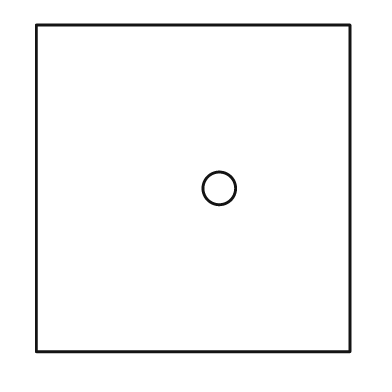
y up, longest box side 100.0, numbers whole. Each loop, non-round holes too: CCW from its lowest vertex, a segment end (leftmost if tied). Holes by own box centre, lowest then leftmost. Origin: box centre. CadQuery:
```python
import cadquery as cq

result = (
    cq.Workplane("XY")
    .moveTo(-48.0, -50.0)
    .lineTo(48.0, -50.0)
    .lineTo(48.0, 50.0)
    .lineTo(-48.0, 50.0)
    .close()
    .moveTo(8.0, 0.0)
    .circle(5.0)
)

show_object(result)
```